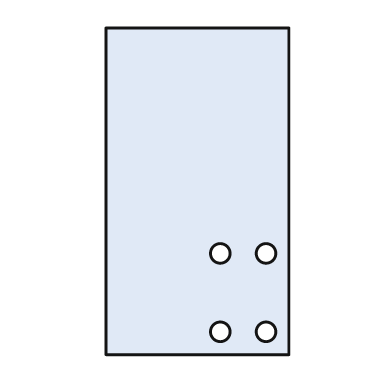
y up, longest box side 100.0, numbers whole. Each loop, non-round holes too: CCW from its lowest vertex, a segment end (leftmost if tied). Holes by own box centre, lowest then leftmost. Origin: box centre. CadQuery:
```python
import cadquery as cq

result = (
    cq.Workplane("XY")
    .moveTo(-28.0, -50.0)
    .lineTo(28.0, -50.0)
    .lineTo(28.0, 50.0)
    .lineTo(-28.0, 50.0)
    .close()
    .moveTo(7.0, -43.0)
    .circle(3.0)
    .moveTo(21.0, -43.0)
    .circle(3.0)
    .moveTo(7.0, -19.0)
    .circle(3.0)
    .moveTo(21.0, -19.0)
    .circle(3.0)
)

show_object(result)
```